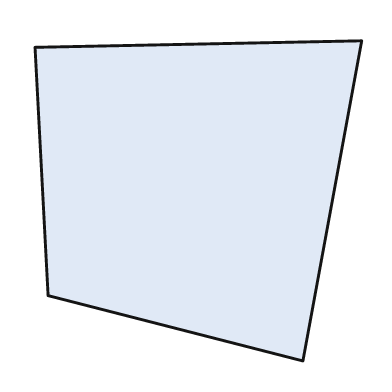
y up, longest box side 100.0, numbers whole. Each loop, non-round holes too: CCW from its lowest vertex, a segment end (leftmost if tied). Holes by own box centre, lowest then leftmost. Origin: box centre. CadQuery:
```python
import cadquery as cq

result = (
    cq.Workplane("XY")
    .moveTo(32.0, -49.0)
    .lineTo(50.0, 49.0)
    .lineTo(-50.0, 47.0)
    .lineTo(-46.0, -29.0)
    .close()
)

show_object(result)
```